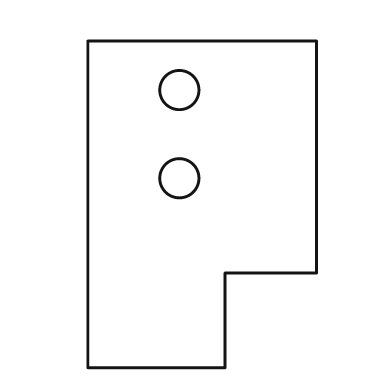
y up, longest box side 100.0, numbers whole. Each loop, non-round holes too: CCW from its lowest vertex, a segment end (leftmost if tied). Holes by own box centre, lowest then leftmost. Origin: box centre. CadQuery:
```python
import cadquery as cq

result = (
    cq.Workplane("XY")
    .moveTo(-35.0, -50.0)
    .lineTo(7.0, -50.0)
    .lineTo(7.0, -21.0)
    .lineTo(35.0, -21.0)
    .lineTo(35.0, 50.0)
    .lineTo(-35.0, 50.0)
    .close()
    .moveTo(-7.0, 8.0)
    .circle(6.0)
    .moveTo(-7.0, 35.0)
    .circle(6.0)
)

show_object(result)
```